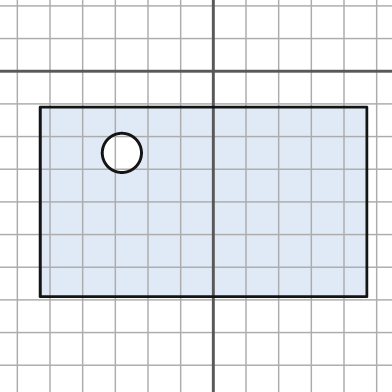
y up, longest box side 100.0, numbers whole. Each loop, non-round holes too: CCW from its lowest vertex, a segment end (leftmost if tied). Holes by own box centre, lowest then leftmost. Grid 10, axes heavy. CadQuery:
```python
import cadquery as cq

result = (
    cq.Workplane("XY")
    .moveTo(-53.0, -69.0)
    .lineTo(47.0, -69.0)
    .lineTo(47.0, -11.0)
    .lineTo(-53.0, -11.0)
    .close()
    .moveTo(-28.0, -25.0)
    .circle(6.0)
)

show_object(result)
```